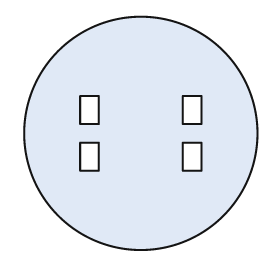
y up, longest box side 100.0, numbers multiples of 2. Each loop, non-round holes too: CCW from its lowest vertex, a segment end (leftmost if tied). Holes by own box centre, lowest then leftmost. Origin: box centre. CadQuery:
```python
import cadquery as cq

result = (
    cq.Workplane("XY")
    .moveTo(0.0, 0.0)
    .circle(50.0)
    .moveTo(-26.0, -16.0)
    .lineTo(-18.0, -16.0)
    .lineTo(-18.0, -4.0)
    .lineTo(-26.0, -4.0)
    .close()
    .moveTo(18.0, -16.0)
    .lineTo(26.0, -16.0)
    .lineTo(26.0, -4.0)
    .lineTo(18.0, -4.0)
    .close()
    .moveTo(-26.0, 4.0)
    .lineTo(-18.0, 4.0)
    .lineTo(-18.0, 16.0)
    .lineTo(-26.0, 16.0)
    .close()
    .moveTo(18.0, 4.0)
    .lineTo(26.0, 4.0)
    .lineTo(26.0, 16.0)
    .lineTo(18.0, 16.0)
    .close()
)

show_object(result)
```